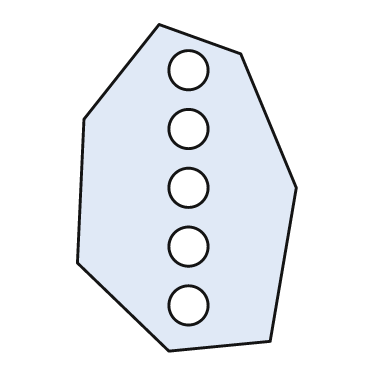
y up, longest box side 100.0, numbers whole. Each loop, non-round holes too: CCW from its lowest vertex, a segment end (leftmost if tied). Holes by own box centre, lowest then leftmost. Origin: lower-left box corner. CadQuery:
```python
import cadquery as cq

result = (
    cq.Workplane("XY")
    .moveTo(28.0, 0.0)
    .lineTo(59.0, 3.0)
    .lineTo(67.0, 50.0)
    .lineTo(50.0, 91.0)
    .lineTo(25.0, 100.0)
    .lineTo(2.0, 71.0)
    .lineTo(0.0, 27.0)
    .close()
    .moveTo(34.0, 14.0)
    .circle(6.0)
    .moveTo(34.0, 32.0)
    .circle(6.0)
    .moveTo(34.0, 50.0)
    .circle(6.0)
    .moveTo(34.0, 68.0)
    .circle(6.0)
    .moveTo(34.0, 86.0)
    .circle(6.0)
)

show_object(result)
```